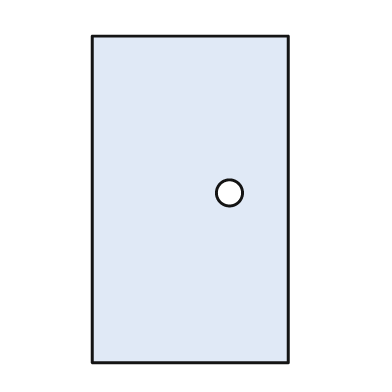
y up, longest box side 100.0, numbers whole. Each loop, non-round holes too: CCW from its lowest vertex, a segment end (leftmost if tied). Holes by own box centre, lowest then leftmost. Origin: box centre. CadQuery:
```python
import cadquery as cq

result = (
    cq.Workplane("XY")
    .moveTo(-30.0, -50.0)
    .lineTo(30.0, -50.0)
    .lineTo(30.0, 50.0)
    .lineTo(-30.0, 50.0)
    .close()
    .moveTo(12.0, 2.0)
    .circle(4.0)
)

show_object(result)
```